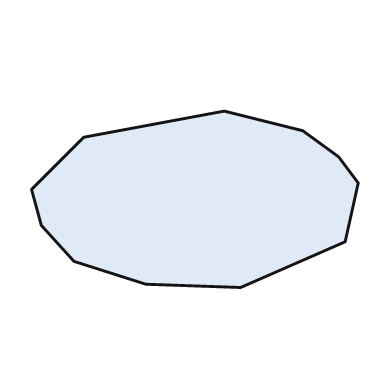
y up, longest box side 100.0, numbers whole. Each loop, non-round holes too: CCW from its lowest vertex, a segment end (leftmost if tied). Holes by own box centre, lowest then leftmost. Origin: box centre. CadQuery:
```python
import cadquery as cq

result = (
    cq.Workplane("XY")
    .moveTo(14.0, -27.0)
    .lineTo(46.0, -13.0)
    .lineTo(50.0, 5.0)
    .lineTo(44.0, 13.0)
    .lineTo(33.0, 21.0)
    .lineTo(9.0, 27.0)
    .lineTo(-34.0, 19.0)
    .lineTo(-50.0, 3.0)
    .lineTo(-47.0, -8.0)
    .lineTo(-37.0, -19.0)
    .lineTo(-15.0, -26.0)
    .close()
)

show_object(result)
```